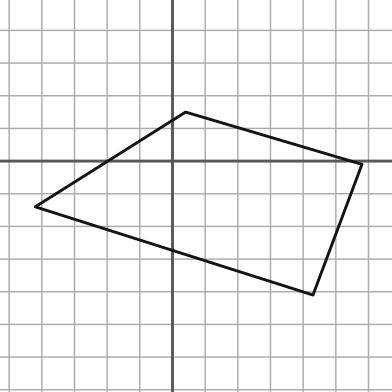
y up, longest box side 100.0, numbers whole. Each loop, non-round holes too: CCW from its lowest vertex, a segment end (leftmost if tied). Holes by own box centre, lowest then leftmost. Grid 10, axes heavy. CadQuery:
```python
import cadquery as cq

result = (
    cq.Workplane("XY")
    .moveTo(43.0, -41.0)
    .lineTo(58.0, -1.0)
    .lineTo(4.0, 15.0)
    .lineTo(-42.0, -14.0)
    .close()
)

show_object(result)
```